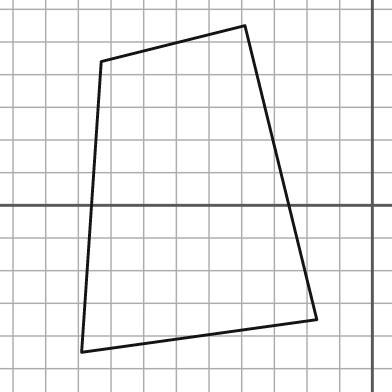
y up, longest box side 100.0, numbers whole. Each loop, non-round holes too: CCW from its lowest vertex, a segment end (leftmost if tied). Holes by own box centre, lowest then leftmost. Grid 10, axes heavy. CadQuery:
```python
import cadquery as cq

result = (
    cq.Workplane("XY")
    .moveTo(-89.0, -45.0)
    .lineTo(-17.0, -35.0)
    .lineTo(-39.0, 55.0)
    .lineTo(-83.0, 44.0)
    .close()
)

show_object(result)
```